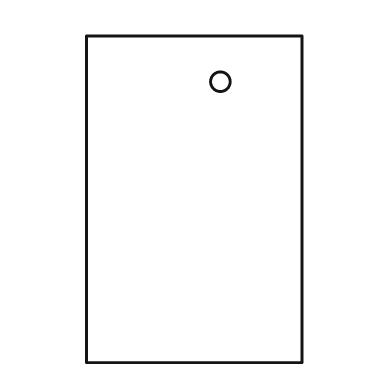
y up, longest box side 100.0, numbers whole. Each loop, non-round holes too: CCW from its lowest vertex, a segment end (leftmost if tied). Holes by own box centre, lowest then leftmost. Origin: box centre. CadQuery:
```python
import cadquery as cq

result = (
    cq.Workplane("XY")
    .moveTo(-33.0, -50.0)
    .lineTo(33.0, -50.0)
    .lineTo(33.0, 50.0)
    .lineTo(-33.0, 50.0)
    .close()
    .moveTo(8.0, 36.0)
    .circle(3.0)
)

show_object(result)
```